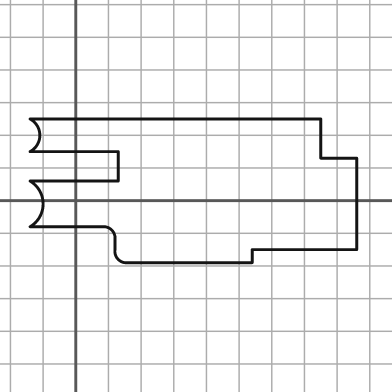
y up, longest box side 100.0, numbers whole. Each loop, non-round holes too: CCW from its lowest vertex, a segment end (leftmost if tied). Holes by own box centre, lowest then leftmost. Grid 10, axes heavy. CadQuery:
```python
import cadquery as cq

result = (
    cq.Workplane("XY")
    .moveTo(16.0, -19.0)
    .lineTo(54.0, -19.0)
    .lineTo(54.0, -15.0)
    .lineTo(86.0, -15.0)
    .lineTo(86.0, 13.0)
    .lineTo(75.0, 13.0)
    .lineTo(75.0, 25.0)
    .lineTo(-14.0, 25.0)
    .threePointArc((-11.0, 20.0), (-14.0, 15.0))
    .lineTo(13.0, 15.0)
    .lineTo(13.0, 6.0)
    .lineTo(-14.0, 6.0)
    .threePointArc((-10.0, -1.0), (-14.0, -8.0))
    .lineTo(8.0, -8.0)
    .threePointArc((11.0, -9.0), (12.0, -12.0))
    .lineTo(12.0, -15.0)
    .threePointArc((13.0, -18.0), (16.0, -19.0))
    .close()
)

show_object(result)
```